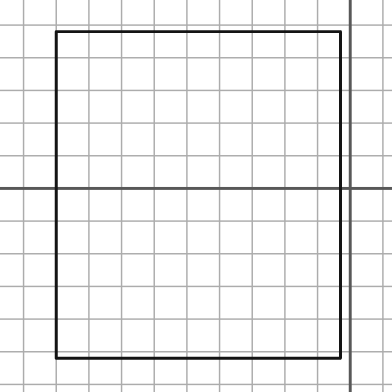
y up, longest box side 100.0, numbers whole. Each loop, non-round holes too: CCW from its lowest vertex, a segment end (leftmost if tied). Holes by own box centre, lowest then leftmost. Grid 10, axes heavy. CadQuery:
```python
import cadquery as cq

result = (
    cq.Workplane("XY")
    .moveTo(-90.0, -52.0)
    .lineTo(-3.0, -52.0)
    .lineTo(-3.0, 48.0)
    .lineTo(-90.0, 48.0)
    .close()
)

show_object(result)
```